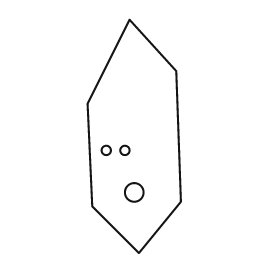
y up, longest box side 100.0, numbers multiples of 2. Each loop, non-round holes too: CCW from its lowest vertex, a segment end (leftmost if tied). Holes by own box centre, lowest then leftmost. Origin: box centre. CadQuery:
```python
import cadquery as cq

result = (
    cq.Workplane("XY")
    .moveTo(2.0, -50.0)
    .lineTo(20.0, -28.0)
    .lineTo(18.0, 28.0)
    .lineTo(-2.0, 50.0)
    .lineTo(-20.0, 14.0)
    .lineTo(-18.0, -30.0)
    .close()
    .moveTo(0.0, -24.0)
    .circle(4.0)
    .moveTo(-12.0, -6.0)
    .circle(2.0)
    .moveTo(-4.0, -6.0)
    .circle(2.0)
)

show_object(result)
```